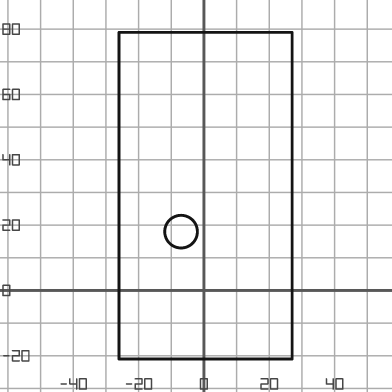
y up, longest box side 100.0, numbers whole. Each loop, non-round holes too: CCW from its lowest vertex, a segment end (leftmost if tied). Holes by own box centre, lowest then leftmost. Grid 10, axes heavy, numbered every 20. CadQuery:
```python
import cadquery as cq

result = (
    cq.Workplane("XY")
    .moveTo(-26.0, -21.0)
    .lineTo(27.0, -21.0)
    .lineTo(27.0, 79.0)
    .lineTo(-26.0, 79.0)
    .close()
    .moveTo(-7.0, 18.0)
    .circle(5.0)
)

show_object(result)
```